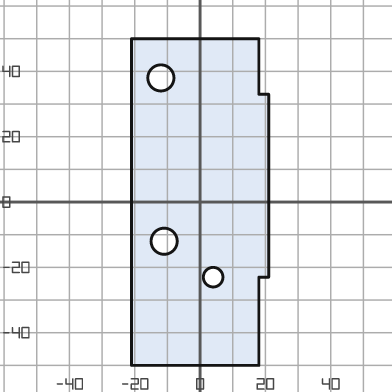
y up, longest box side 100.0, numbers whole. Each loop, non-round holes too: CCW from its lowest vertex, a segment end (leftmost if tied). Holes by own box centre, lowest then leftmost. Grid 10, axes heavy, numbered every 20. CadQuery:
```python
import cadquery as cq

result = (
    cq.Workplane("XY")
    .moveTo(-21.0, -50.0)
    .lineTo(18.0, -50.0)
    .lineTo(18.0, -23.0)
    .lineTo(21.0, -23.0)
    .lineTo(21.0, 33.0)
    .lineTo(18.0, 33.0)
    .lineTo(18.0, 50.0)
    .lineTo(-21.0, 50.0)
    .close()
    .moveTo(4.0, -23.0)
    .circle(3.0)
    .moveTo(-11.0, -12.0)
    .circle(4.0)
    .moveTo(-12.0, 38.0)
    .circle(4.0)
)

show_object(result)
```